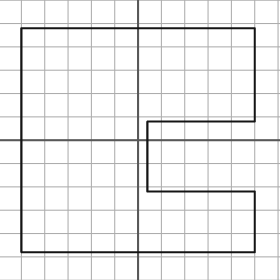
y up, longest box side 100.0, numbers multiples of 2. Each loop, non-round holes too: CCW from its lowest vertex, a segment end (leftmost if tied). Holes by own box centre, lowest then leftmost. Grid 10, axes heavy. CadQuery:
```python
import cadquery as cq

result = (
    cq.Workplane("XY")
    .moveTo(-50.0, -48.0)
    .lineTo(50.0, -48.0)
    .lineTo(50.0, -22.0)
    .lineTo(4.0, -22.0)
    .lineTo(4.0, 8.0)
    .lineTo(50.0, 8.0)
    .lineTo(50.0, 48.0)
    .lineTo(-50.0, 48.0)
    .close()
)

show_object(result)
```